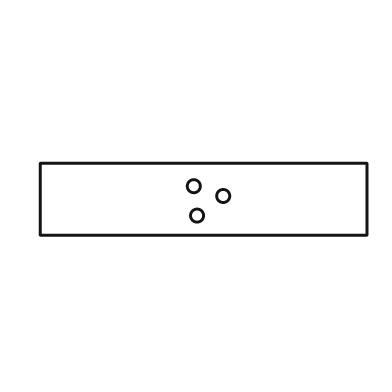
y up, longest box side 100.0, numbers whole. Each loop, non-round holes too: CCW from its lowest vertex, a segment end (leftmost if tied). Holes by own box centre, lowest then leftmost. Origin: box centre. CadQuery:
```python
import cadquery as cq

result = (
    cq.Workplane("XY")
    .moveTo(-50.0, -11.0)
    .lineTo(50.0, -11.0)
    .lineTo(50.0, 11.0)
    .lineTo(-50.0, 11.0)
    .close()
    .moveTo(-2.0, -5.0)
    .circle(2.0)
    .moveTo(6.0, 1.0)
    .circle(2.0)
    .moveTo(-3.0, 4.0)
    .circle(2.0)
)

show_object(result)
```